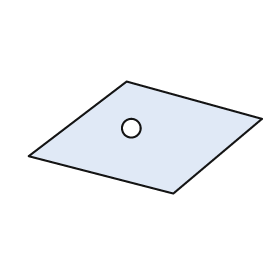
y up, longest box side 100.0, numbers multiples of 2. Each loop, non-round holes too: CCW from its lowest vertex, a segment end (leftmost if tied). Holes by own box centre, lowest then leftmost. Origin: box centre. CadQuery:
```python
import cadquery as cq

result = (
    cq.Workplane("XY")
    .moveTo(12.0, -24.0)
    .lineTo(50.0, 8.0)
    .lineTo(-8.0, 24.0)
    .lineTo(-50.0, -8.0)
    .close()
    .moveTo(-6.0, 4.0)
    .circle(4.0)
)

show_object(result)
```